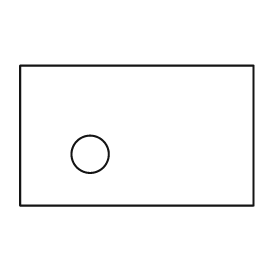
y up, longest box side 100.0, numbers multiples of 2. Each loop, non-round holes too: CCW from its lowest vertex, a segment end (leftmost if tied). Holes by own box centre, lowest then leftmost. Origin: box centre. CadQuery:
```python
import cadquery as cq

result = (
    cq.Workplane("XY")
    .moveTo(-50.0, -30.0)
    .lineTo(50.0, -30.0)
    .lineTo(50.0, 30.0)
    .lineTo(-50.0, 30.0)
    .close()
    .moveTo(-20.0, -8.0)
    .circle(8.0)
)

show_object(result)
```